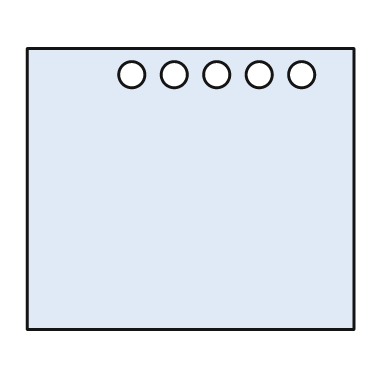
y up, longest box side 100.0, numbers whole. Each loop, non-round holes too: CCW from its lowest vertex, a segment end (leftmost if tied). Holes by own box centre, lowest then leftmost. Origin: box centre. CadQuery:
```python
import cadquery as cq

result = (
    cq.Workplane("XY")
    .moveTo(-50.0, -43.0)
    .lineTo(50.0, -43.0)
    .lineTo(50.0, 43.0)
    .lineTo(-50.0, 43.0)
    .close()
    .moveTo(-18.0, 35.0)
    .circle(4.0)
    .moveTo(-5.0, 35.0)
    .circle(4.0)
    .moveTo(8.0, 35.0)
    .circle(4.0)
    .moveTo(21.0, 35.0)
    .circle(4.0)
    .moveTo(34.0, 35.0)
    .circle(4.0)
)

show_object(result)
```